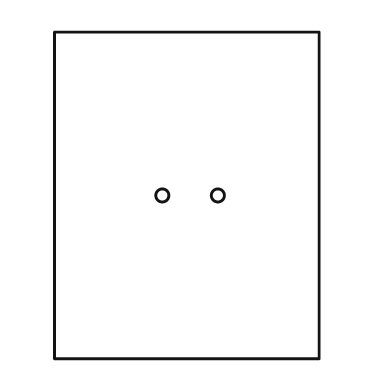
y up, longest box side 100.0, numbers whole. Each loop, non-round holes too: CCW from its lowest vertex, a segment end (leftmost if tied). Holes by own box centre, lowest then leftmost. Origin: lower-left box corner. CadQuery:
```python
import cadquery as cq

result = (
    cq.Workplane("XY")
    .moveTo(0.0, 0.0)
    .lineTo(81.0, 0.0)
    .lineTo(81.0, 100.0)
    .lineTo(0.0, 100.0)
    .close()
    .moveTo(33.0, 50.0)
    .circle(2.0)
    .moveTo(50.0, 50.0)
    .circle(2.0)
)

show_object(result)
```